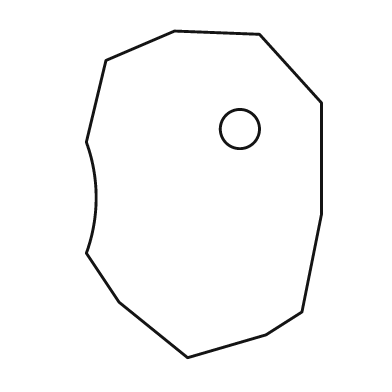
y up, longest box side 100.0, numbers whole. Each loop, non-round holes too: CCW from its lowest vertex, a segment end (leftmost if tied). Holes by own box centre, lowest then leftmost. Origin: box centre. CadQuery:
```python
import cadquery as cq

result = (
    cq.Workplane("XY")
    .moveTo(-5.0, -50.0)
    .lineTo(19.0, -43.0)
    .lineTo(30.0, -36.0)
    .lineTo(36.0, -6.0)
    .lineTo(36.0, 28.0)
    .lineTo(17.0, 49.0)
    .lineTo(-9.0, 50.0)
    .lineTo(-30.0, 41.0)
    .lineTo(-36.0, 16.0)
    .threePointArc((-33.0, -1.0), (-36.0, -18.0))
    .lineTo(-26.0, -33.0)
    .close()
    .moveTo(11.0, 20.0)
    .circle(6.0)
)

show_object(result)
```